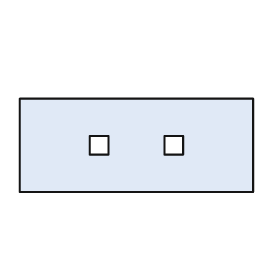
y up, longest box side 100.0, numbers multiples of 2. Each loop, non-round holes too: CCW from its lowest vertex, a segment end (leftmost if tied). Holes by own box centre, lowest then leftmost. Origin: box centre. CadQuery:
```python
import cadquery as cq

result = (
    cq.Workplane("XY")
    .moveTo(-50.0, -20.0)
    .lineTo(50.0, -20.0)
    .lineTo(50.0, 20.0)
    .lineTo(-50.0, 20.0)
    .close()
    .moveTo(-20.0, -4.0)
    .lineTo(-12.0, -4.0)
    .lineTo(-12.0, 4.0)
    .lineTo(-20.0, 4.0)
    .close()
    .moveTo(12.0, -4.0)
    .lineTo(20.0, -4.0)
    .lineTo(20.0, 4.0)
    .lineTo(12.0, 4.0)
    .close()
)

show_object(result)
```